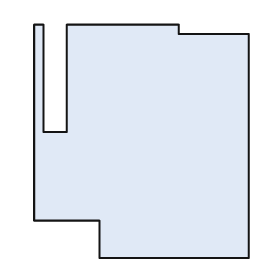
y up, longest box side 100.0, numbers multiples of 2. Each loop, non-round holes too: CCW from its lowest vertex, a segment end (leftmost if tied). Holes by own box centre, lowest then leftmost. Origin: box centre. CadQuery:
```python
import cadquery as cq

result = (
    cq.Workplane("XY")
    .moveTo(-18.0, -50.0)
    .lineTo(46.0, -50.0)
    .lineTo(46.0, 46.0)
    .lineTo(16.0, 46.0)
    .lineTo(16.0, 50.0)
    .lineTo(-32.0, 50.0)
    .lineTo(-32.0, 4.0)
    .lineTo(-42.0, 4.0)
    .lineTo(-42.0, 50.0)
    .lineTo(-46.0, 50.0)
    .lineTo(-46.0, -34.0)
    .lineTo(-18.0, -34.0)
    .close()
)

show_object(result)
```